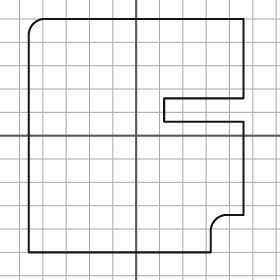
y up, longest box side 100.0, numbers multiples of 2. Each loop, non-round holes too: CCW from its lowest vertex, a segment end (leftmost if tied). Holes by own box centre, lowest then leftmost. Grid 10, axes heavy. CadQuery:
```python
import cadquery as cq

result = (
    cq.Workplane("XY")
    .moveTo(-46.0, -50.0)
    .lineTo(32.0, -50.0)
    .lineTo(32.0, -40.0)
    .threePointArc((34.0, -36.0), (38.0, -34.0))
    .lineTo(46.0, -34.0)
    .lineTo(46.0, 6.0)
    .lineTo(12.0, 6.0)
    .lineTo(12.0, 16.0)
    .lineTo(46.0, 16.0)
    .lineTo(46.0, 50.0)
    .lineTo(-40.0, 50.0)
    .threePointArc((-44.0, 48.0), (-46.0, 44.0))
    .close()
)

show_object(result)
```